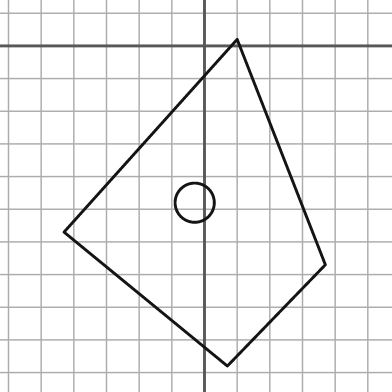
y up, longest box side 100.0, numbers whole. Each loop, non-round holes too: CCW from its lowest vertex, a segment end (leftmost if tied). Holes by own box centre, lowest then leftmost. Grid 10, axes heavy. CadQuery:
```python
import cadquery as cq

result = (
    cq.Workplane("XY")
    .moveTo(7.0, -98.0)
    .lineTo(37.0, -67.0)
    .lineTo(10.0, 2.0)
    .lineTo(-43.0, -57.0)
    .close()
    .moveTo(-3.0, -48.0)
    .circle(6.0)
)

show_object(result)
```